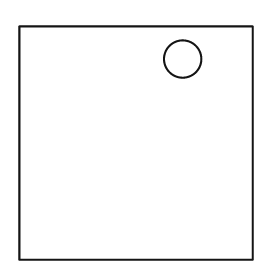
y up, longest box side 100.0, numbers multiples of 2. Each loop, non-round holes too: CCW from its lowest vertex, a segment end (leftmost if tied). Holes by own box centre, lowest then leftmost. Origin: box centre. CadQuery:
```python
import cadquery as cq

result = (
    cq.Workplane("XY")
    .moveTo(-50.0, -50.0)
    .lineTo(50.0, -50.0)
    .lineTo(50.0, 50.0)
    .lineTo(-50.0, 50.0)
    .close()
    .moveTo(20.0, 36.0)
    .circle(8.0)
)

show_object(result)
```